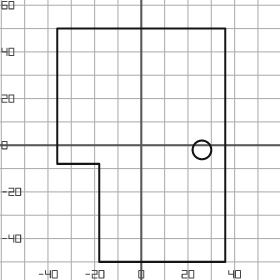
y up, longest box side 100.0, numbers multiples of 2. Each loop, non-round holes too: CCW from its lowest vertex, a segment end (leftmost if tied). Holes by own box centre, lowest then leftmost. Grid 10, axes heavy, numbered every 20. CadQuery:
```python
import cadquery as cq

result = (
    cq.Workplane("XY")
    .moveTo(-18.0, -50.0)
    .lineTo(36.0, -50.0)
    .lineTo(36.0, 50.0)
    .lineTo(-36.0, 50.0)
    .lineTo(-36.0, -8.0)
    .lineTo(-18.0, -8.0)
    .close()
    .moveTo(26.0, -2.0)
    .circle(4.0)
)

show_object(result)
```